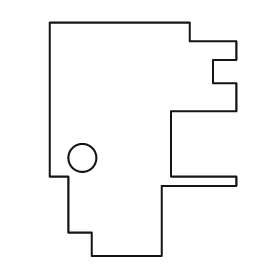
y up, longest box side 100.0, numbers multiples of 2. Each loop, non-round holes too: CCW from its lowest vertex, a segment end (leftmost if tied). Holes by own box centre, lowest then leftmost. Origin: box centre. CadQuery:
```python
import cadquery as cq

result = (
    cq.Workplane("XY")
    .moveTo(-22.0, -50.0)
    .lineTo(8.0, -50.0)
    .lineTo(8.0, -20.0)
    .lineTo(40.0, -20.0)
    .lineTo(40.0, -16.0)
    .lineTo(12.0, -16.0)
    .lineTo(12.0, 12.0)
    .lineTo(40.0, 12.0)
    .lineTo(40.0, 24.0)
    .lineTo(30.0, 24.0)
    .lineTo(30.0, 34.0)
    .lineTo(40.0, 34.0)
    .lineTo(40.0, 42.0)
    .lineTo(20.0, 42.0)
    .lineTo(20.0, 50.0)
    .lineTo(-40.0, 50.0)
    .lineTo(-40.0, -16.0)
    .lineTo(-32.0, -16.0)
    .lineTo(-32.0, -40.0)
    .lineTo(-22.0, -40.0)
    .close()
    .moveTo(-26.0, -8.0)
    .circle(6.0)
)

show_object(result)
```